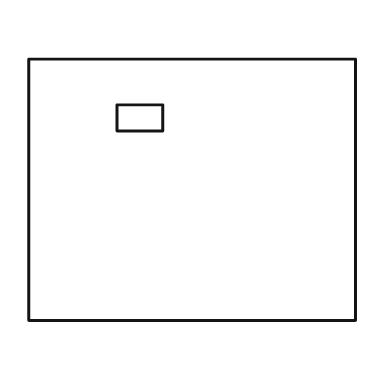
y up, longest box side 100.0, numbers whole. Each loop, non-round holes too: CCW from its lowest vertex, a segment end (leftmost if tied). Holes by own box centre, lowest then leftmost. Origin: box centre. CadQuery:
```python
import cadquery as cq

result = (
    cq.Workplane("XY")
    .moveTo(-50.0, -40.0)
    .lineTo(50.0, -40.0)
    .lineTo(50.0, 40.0)
    .lineTo(-50.0, 40.0)
    .close()
    .moveTo(-23.0, 18.0)
    .lineTo(-9.0, 18.0)
    .lineTo(-9.0, 26.0)
    .lineTo(-23.0, 26.0)
    .close()
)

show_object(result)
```